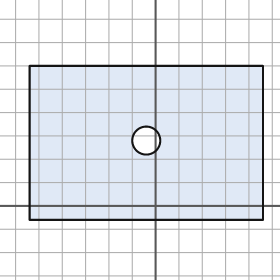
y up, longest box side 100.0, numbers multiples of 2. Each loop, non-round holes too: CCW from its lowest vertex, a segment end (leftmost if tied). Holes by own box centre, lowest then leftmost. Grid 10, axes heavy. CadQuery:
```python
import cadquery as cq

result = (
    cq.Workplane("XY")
    .moveTo(-54.0, -6.0)
    .lineTo(46.0, -6.0)
    .lineTo(46.0, 60.0)
    .lineTo(-54.0, 60.0)
    .close()
    .moveTo(-4.0, 28.0)
    .circle(6.0)
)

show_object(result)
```